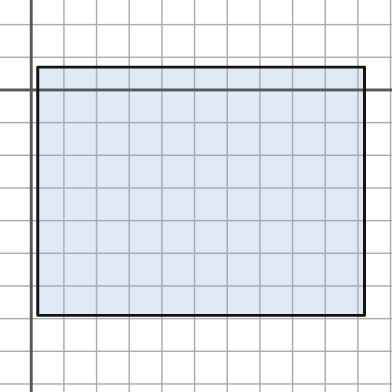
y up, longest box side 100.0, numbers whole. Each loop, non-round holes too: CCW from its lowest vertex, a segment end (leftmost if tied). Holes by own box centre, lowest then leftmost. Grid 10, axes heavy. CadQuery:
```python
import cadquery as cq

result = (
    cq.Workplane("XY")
    .moveTo(2.0, -69.0)
    .lineTo(102.0, -69.0)
    .lineTo(102.0, 7.0)
    .lineTo(2.0, 7.0)
    .close()
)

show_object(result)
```